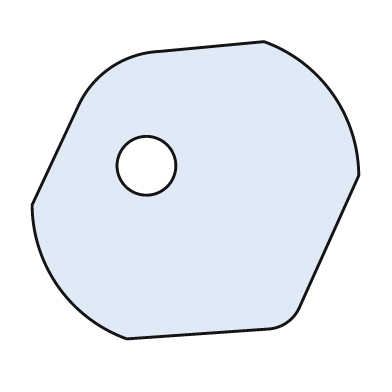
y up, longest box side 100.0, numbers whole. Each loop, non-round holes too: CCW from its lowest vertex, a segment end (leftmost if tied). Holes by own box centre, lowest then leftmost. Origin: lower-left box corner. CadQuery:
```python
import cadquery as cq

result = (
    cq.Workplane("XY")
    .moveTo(29.0, 0.0)
    .lineTo(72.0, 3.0)
    .threePointArc((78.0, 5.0), (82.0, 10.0))
    .lineTo(100.0, 50.0)
    .threePointArc((92.0, 75.0), (71.0, 91.0))
    .lineTo(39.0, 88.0)
    .threePointArc((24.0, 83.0), (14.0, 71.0))
    .lineTo(0.0, 41.0)
    .threePointArc((8.0, 16.0), (29.0, 0.0))
    .close()
    .moveTo(35.0, 53.0)
    .circle(9.0)
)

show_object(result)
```